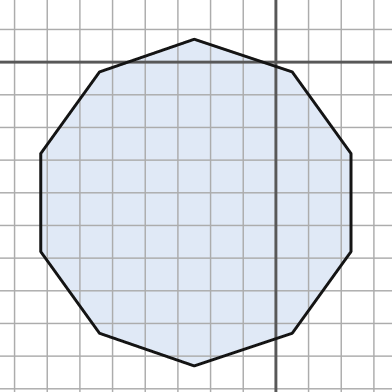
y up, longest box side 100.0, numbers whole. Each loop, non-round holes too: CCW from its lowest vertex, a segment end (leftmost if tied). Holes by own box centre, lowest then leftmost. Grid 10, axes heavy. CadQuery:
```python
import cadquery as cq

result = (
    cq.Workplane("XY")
    .moveTo(-25.0, -93.0)
    .lineTo(5.0, -83.0)
    .lineTo(23.0, -58.0)
    .lineTo(23.0, -28.0)
    .lineTo(5.0, -3.0)
    .lineTo(-25.0, 7.0)
    .lineTo(-54.0, -3.0)
    .lineTo(-72.0, -28.0)
    .lineTo(-72.0, -58.0)
    .lineTo(-54.0, -83.0)
    .close()
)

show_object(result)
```